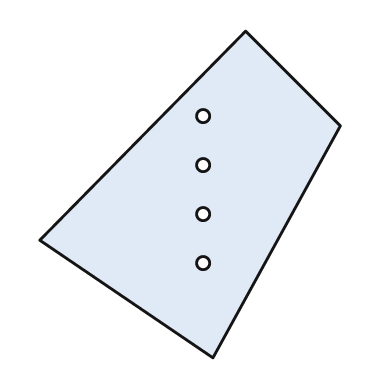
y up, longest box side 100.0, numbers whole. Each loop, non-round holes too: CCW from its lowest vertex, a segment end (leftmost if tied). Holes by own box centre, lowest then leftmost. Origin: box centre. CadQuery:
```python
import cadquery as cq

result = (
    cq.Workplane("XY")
    .moveTo(7.0, -50.0)
    .lineTo(46.0, 21.0)
    .lineTo(17.0, 50.0)
    .lineTo(-46.0, -14.0)
    .close()
    .moveTo(4.0, -21.0)
    .circle(2.0)
    .moveTo(4.0, -6.0)
    .circle(2.0)
    .moveTo(4.0, 9.0)
    .circle(2.0)
    .moveTo(4.0, 24.0)
    .circle(2.0)
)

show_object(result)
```